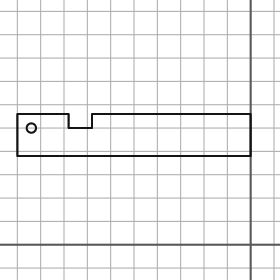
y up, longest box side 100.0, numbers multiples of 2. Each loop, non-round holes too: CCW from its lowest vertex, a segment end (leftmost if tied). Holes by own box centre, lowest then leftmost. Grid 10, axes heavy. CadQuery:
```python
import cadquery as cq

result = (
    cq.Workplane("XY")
    .moveTo(-100.0, 38.0)
    .lineTo(0.0, 38.0)
    .lineTo(0.0, 56.0)
    .lineTo(-68.0, 56.0)
    .lineTo(-68.0, 50.0)
    .lineTo(-78.0, 50.0)
    .lineTo(-78.0, 56.0)
    .lineTo(-100.0, 56.0)
    .close()
    .moveTo(-94.0, 50.0)
    .circle(2.0)
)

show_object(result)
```